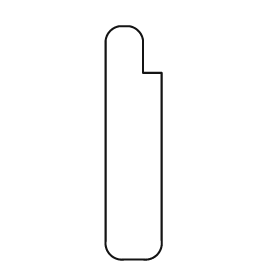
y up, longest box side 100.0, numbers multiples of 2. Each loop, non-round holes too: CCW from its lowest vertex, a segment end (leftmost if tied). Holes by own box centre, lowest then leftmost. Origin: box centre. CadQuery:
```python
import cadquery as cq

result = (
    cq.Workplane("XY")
    .moveTo(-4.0, -50.0)
    .lineTo(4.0, -50.0)
    .threePointArc((10.0, -48.0), (12.0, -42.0))
    .lineTo(12.0, 30.0)
    .lineTo(4.0, 30.0)
    .lineTo(4.0, 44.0)
    .threePointArc((2.0, 48.0), (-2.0, 50.0))
    .lineTo(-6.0, 50.0)
    .threePointArc((-10.0, 48.0), (-12.0, 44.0))
    .lineTo(-12.0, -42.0)
    .threePointArc((-10.0, -48.0), (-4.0, -50.0))
    .close()
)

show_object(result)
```